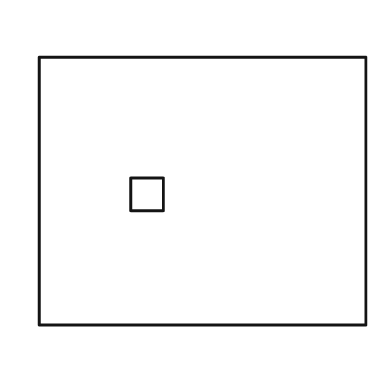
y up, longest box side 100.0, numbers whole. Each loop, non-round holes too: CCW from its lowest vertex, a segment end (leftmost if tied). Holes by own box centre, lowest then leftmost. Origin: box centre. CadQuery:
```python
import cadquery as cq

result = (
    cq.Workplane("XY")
    .moveTo(-50.0, -41.0)
    .lineTo(50.0, -41.0)
    .lineTo(50.0, 41.0)
    .lineTo(-50.0, 41.0)
    .close()
    .moveTo(-22.0, -6.0)
    .lineTo(-12.0, -6.0)
    .lineTo(-12.0, 4.0)
    .lineTo(-22.0, 4.0)
    .close()
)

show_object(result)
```